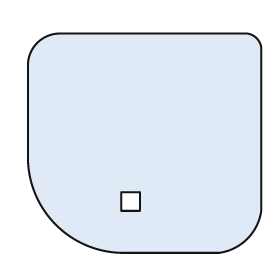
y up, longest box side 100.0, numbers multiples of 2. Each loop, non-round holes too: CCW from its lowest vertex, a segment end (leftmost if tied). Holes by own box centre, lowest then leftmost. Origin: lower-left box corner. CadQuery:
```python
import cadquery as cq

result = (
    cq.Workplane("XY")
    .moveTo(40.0, 0.0)
    .lineTo(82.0, 0.0)
    .threePointArc((94.0, 6.0), (100.0, 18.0))
    .lineTo(100.0, 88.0)
    .threePointArc((98.0, 92.0), (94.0, 94.0))
    .lineTo(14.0, 94.0)
    .threePointArc((4.0, 90.0), (0.0, 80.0))
    .lineTo(0.0, 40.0)
    .threePointArc((12.0, 12.0), (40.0, 0.0))
    .close()
    .moveTo(40.0, 18.0)
    .lineTo(48.0, 18.0)
    .lineTo(48.0, 26.0)
    .lineTo(40.0, 26.0)
    .close()
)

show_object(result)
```